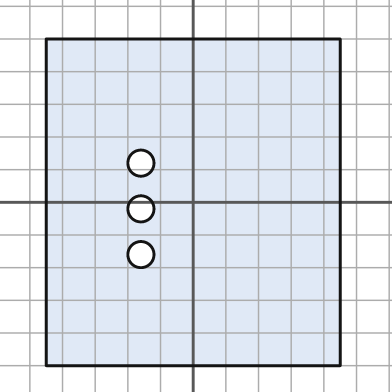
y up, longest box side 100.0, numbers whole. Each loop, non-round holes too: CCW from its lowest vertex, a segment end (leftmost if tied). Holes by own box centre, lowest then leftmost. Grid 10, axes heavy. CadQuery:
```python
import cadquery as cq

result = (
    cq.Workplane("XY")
    .moveTo(-45.0, -50.0)
    .lineTo(45.0, -50.0)
    .lineTo(45.0, 50.0)
    .lineTo(-45.0, 50.0)
    .close()
    .moveTo(-16.0, -16.0)
    .circle(4.0)
    .moveTo(-16.0, -2.0)
    .circle(4.0)
    .moveTo(-16.0, 12.0)
    .circle(4.0)
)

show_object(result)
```